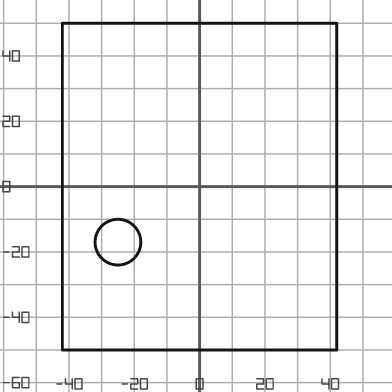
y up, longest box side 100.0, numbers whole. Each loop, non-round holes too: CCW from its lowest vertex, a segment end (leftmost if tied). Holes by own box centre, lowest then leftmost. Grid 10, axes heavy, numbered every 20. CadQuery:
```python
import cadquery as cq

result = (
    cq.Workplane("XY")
    .moveTo(-42.0, -50.0)
    .lineTo(42.0, -50.0)
    .lineTo(42.0, 50.0)
    .lineTo(-42.0, 50.0)
    .close()
    .moveTo(-25.0, -17.0)
    .circle(7.0)
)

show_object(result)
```